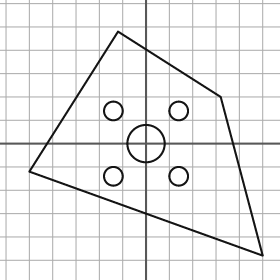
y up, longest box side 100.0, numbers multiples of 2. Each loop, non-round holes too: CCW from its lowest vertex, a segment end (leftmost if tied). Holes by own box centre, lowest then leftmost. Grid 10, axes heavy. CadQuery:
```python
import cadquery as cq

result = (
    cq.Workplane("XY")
    .moveTo(50.0, -48.0)
    .lineTo(32.0, 20.0)
    .lineTo(-12.0, 48.0)
    .lineTo(-50.0, -12.0)
    .close()
    .moveTo(-14.0, -14.0)
    .circle(4.0)
    .moveTo(14.0, -14.0)
    .circle(4.0)
    .moveTo(0.0, 0.0)
    .circle(8.0)
    .moveTo(-14.0, 14.0)
    .circle(4.0)
    .moveTo(14.0, 14.0)
    .circle(4.0)
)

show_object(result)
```